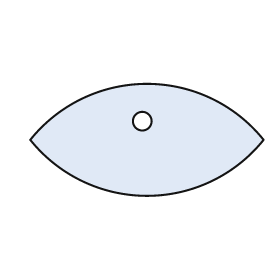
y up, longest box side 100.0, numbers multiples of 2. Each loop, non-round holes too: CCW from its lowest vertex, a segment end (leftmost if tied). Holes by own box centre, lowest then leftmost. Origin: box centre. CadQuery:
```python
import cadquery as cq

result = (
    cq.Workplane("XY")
    .moveTo(-50.0, 0.0)
    .threePointArc((0.0, -24.0), (50.0, 0.0))
    .threePointArc((0.0, 24.0), (-50.0, 0.0))
    .close()
    .moveTo(-2.0, 8.0)
    .circle(4.0)
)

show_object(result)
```